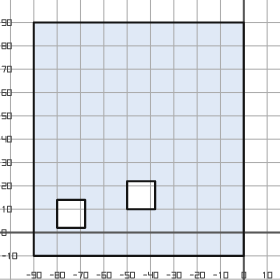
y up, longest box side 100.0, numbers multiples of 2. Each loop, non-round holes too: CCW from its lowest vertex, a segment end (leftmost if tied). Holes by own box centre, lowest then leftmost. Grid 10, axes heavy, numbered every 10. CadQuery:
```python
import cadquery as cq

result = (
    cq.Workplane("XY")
    .moveTo(-90.0, -10.0)
    .lineTo(0.0, -10.0)
    .lineTo(0.0, 90.0)
    .lineTo(-90.0, 90.0)
    .close()
    .moveTo(-80.0, 2.0)
    .lineTo(-68.0, 2.0)
    .lineTo(-68.0, 14.0)
    .lineTo(-80.0, 14.0)
    .close()
    .moveTo(-50.0, 10.0)
    .lineTo(-38.0, 10.0)
    .lineTo(-38.0, 22.0)
    .lineTo(-50.0, 22.0)
    .close()
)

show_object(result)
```